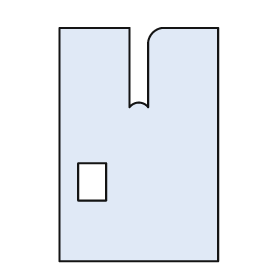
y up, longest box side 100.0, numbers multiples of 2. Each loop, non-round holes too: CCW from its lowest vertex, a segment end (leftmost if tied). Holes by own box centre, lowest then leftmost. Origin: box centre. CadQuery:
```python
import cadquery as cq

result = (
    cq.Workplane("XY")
    .moveTo(-34.0, -50.0)
    .lineTo(34.0, -50.0)
    .lineTo(34.0, 50.0)
    .lineTo(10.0, 50.0)
    .threePointArc((6.0, 48.0), (4.0, 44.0))
    .lineTo(4.0, 16.0)
    .threePointArc((0.0, 18.0), (-4.0, 16.0))
    .lineTo(-4.0, 50.0)
    .lineTo(-34.0, 50.0)
    .close()
    .moveTo(-26.0, -24.0)
    .lineTo(-14.0, -24.0)
    .lineTo(-14.0, -8.0)
    .lineTo(-26.0, -8.0)
    .close()
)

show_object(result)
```